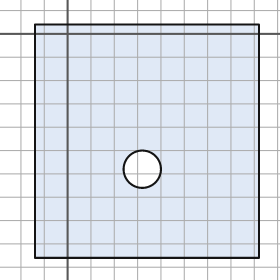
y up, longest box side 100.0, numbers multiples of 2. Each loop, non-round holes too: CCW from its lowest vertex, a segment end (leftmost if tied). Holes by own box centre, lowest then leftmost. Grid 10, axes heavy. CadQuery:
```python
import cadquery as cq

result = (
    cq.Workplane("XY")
    .moveTo(-14.0, -96.0)
    .lineTo(82.0, -96.0)
    .lineTo(82.0, 4.0)
    .lineTo(-14.0, 4.0)
    .close()
    .moveTo(32.0, -58.0)
    .circle(8.0)
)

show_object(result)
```